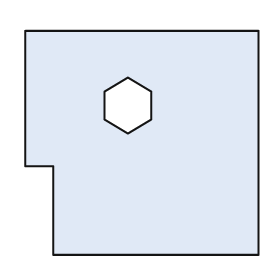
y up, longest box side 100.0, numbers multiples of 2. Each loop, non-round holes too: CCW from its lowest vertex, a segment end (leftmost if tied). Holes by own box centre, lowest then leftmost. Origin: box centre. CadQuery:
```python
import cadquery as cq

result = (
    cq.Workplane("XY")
    .moveTo(-38.0, -48.0)
    .lineTo(50.0, -48.0)
    .lineTo(50.0, 48.0)
    .lineTo(-50.0, 48.0)
    .lineTo(-50.0, -10.0)
    .lineTo(-38.0, -10.0)
    .close()
    .moveTo(-6.0, 4.0)
    .lineTo(4.0, 10.0)
    .lineTo(4.0, 22.0)
    .lineTo(-6.0, 28.0)
    .lineTo(-16.0, 22.0)
    .lineTo(-16.0, 10.0)
    .close()
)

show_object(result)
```